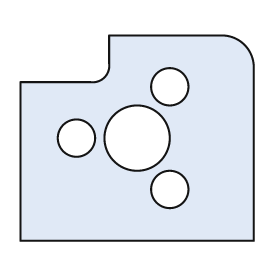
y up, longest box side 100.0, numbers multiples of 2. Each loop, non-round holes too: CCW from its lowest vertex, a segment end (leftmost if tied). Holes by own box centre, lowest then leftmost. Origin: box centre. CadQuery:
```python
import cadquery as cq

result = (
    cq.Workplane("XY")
    .moveTo(-50.0, -44.0)
    .lineTo(50.0, -44.0)
    .lineTo(50.0, 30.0)
    .threePointArc((46.0, 40.0), (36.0, 44.0))
    .lineTo(-12.0, 44.0)
    .lineTo(-12.0, 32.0)
    .threePointArc((-14.0, 26.0), (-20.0, 24.0))
    .lineTo(-50.0, 24.0)
    .close()
    .moveTo(14.0, -22.0)
    .circle(8.0)
    .moveTo(-26.0, 0.0)
    .circle(8.0)
    .moveTo(0.0, 0.0)
    .circle(14.0)
    .moveTo(14.0, 22.0)
    .circle(8.0)
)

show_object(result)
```